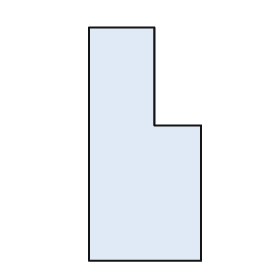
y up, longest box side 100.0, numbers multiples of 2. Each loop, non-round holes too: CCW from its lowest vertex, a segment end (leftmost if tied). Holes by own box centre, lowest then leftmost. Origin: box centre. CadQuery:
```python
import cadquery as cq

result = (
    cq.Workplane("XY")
    .moveTo(-24.0, -50.0)
    .lineTo(24.0, -50.0)
    .lineTo(24.0, 8.0)
    .lineTo(4.0, 8.0)
    .lineTo(4.0, 50.0)
    .lineTo(-24.0, 50.0)
    .close()
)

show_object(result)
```